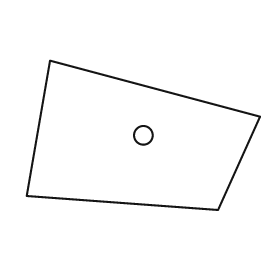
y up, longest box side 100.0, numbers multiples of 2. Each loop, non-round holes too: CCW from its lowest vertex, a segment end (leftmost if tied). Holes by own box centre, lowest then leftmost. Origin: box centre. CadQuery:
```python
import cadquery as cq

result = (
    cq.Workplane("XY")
    .moveTo(32.0, -32.0)
    .lineTo(50.0, 8.0)
    .lineTo(-40.0, 32.0)
    .lineTo(-50.0, -26.0)
    .close()
    .moveTo(0.0, 0.0)
    .circle(4.0)
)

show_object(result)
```